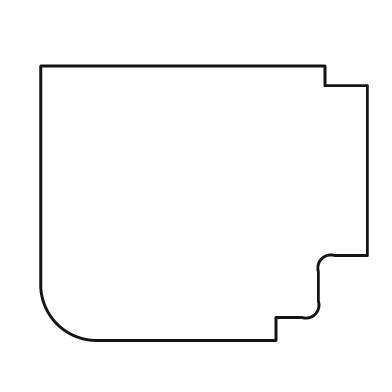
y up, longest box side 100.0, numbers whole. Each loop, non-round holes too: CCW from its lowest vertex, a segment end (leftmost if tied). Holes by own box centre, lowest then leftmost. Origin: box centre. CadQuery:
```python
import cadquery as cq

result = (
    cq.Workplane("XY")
    .moveTo(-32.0, -42.0)
    .lineTo(22.0, -42.0)
    .lineTo(22.0, -35.0)
    .lineTo(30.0, -35.0)
    .threePointArc((34.0, -34.0), (35.0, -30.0))
    .lineTo(35.0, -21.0)
    .threePointArc((36.0, -17.0), (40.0, -16.0))
    .lineTo(50.0, -16.0)
    .lineTo(50.0, 36.0)
    .lineTo(37.0, 36.0)
    .lineTo(37.0, 42.0)
    .lineTo(-50.0, 42.0)
    .lineTo(-50.0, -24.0)
    .threePointArc((-45.0, -37.0), (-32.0, -42.0))
    .close()
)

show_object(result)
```